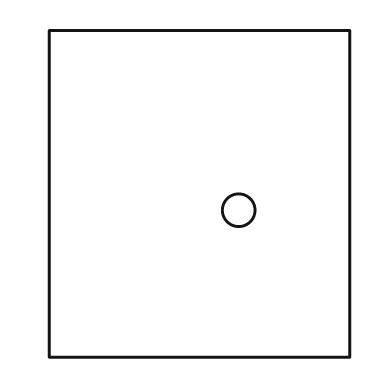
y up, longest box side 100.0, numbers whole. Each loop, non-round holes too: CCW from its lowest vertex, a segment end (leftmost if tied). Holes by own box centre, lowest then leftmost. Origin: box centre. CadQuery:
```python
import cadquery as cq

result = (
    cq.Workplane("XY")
    .moveTo(-46.0, -50.0)
    .lineTo(46.0, -50.0)
    .lineTo(46.0, 50.0)
    .lineTo(-46.0, 50.0)
    .close()
    .moveTo(12.0, -5.0)
    .circle(5.0)
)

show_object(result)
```